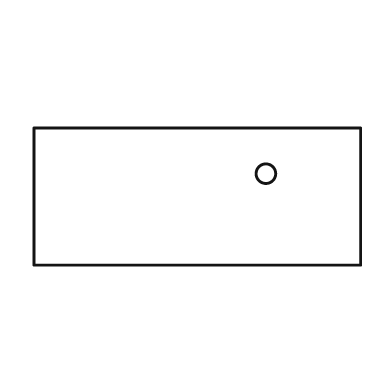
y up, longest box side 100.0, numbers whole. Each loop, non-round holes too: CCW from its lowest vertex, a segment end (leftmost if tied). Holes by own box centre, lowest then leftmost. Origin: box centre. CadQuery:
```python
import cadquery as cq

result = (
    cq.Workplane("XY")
    .moveTo(-50.0, -21.0)
    .lineTo(50.0, -21.0)
    .lineTo(50.0, 21.0)
    .lineTo(-50.0, 21.0)
    .close()
    .moveTo(21.0, 7.0)
    .circle(3.0)
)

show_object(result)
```